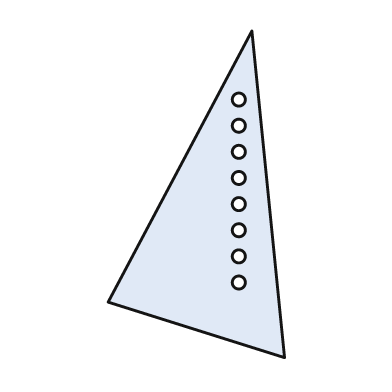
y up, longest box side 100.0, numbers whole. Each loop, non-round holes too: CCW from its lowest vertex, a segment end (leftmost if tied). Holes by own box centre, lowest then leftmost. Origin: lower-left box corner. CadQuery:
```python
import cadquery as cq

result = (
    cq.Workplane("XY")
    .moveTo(54.0, 0.0)
    .lineTo(44.0, 100.0)
    .lineTo(0.0, 17.0)
    .close()
    .moveTo(40.0, 23.0)
    .circle(2.0)
    .moveTo(40.0, 31.0)
    .circle(2.0)
    .moveTo(40.0, 39.0)
    .circle(2.0)
    .moveTo(40.0, 47.0)
    .circle(2.0)
    .moveTo(40.0, 55.0)
    .circle(2.0)
    .moveTo(40.0, 63.0)
    .circle(2.0)
    .moveTo(40.0, 71.0)
    .circle(2.0)
    .moveTo(40.0, 79.0)
    .circle(2.0)
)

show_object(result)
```